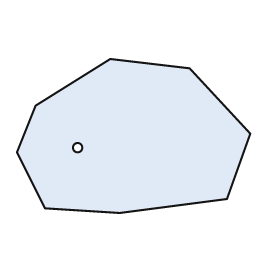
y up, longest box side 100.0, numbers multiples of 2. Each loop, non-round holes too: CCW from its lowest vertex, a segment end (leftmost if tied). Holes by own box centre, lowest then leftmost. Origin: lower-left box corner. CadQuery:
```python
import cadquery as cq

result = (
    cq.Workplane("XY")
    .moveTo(44.0, 0.0)
    .lineTo(90.0, 6.0)
    .lineTo(100.0, 34.0)
    .lineTo(74.0, 62.0)
    .lineTo(40.0, 66.0)
    .lineTo(8.0, 46.0)
    .lineTo(0.0, 26.0)
    .lineTo(12.0, 2.0)
    .close()
    .moveTo(26.0, 28.0)
    .circle(2.0)
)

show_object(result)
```